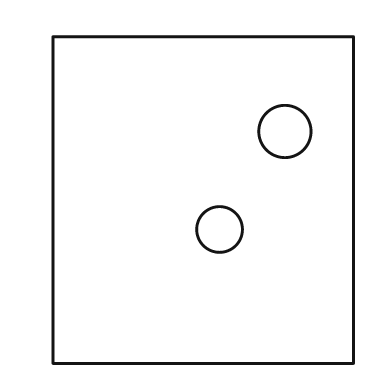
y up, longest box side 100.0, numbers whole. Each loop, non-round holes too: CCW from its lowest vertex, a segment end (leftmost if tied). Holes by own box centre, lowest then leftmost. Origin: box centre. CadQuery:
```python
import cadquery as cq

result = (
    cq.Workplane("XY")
    .moveTo(-46.0, -50.0)
    .lineTo(46.0, -50.0)
    .lineTo(46.0, 50.0)
    .lineTo(-46.0, 50.0)
    .close()
    .moveTo(5.0, -9.0)
    .circle(7.0)
    .moveTo(25.0, 21.0)
    .circle(8.0)
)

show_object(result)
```